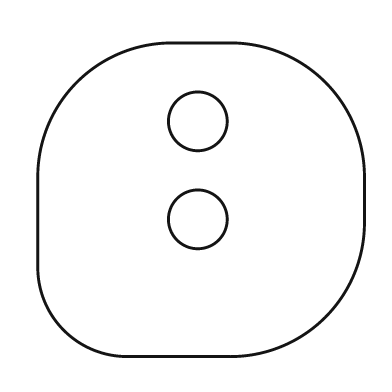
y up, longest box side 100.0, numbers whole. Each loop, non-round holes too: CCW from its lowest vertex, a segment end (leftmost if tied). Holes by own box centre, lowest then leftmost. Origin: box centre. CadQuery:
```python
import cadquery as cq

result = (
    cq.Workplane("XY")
    .moveTo(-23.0, -48.0)
    .lineTo(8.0, -48.0)
    .threePointArc((38.0, -36.0), (50.0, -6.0))
    .lineTo(50.0, 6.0)
    .threePointArc((38.0, 36.0), (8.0, 48.0))
    .lineTo(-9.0, 48.0)
    .threePointArc((-38.0, 36.0), (-50.0, 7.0))
    .lineTo(-50.0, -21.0)
    .threePointArc((-42.0, -40.0), (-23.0, -48.0))
    .close()
    .moveTo(-1.0, -6.0)
    .circle(9.0)
    .moveTo(-1.0, 24.0)
    .circle(9.0)
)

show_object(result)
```